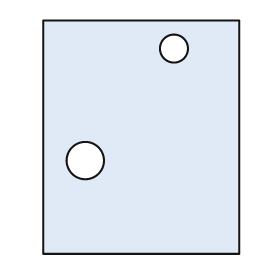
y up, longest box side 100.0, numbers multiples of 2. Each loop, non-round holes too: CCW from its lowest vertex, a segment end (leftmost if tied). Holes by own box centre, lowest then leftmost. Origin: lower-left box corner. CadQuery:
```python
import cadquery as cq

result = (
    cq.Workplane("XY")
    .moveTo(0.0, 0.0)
    .lineTo(84.0, 0.0)
    .lineTo(84.0, 100.0)
    .lineTo(0.0, 100.0)
    .close()
    .moveTo(18.0, 40.0)
    .circle(8.0)
    .moveTo(56.0, 88.0)
    .circle(6.0)
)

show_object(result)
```